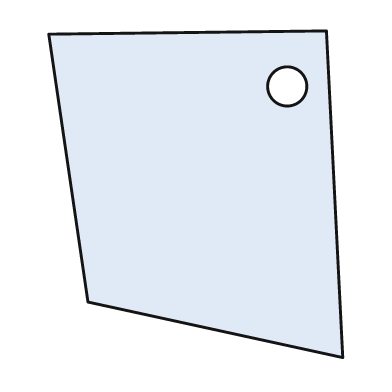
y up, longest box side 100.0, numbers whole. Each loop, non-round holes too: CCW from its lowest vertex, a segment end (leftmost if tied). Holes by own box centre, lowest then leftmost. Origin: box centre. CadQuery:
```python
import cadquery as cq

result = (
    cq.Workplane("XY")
    .moveTo(45.0, -50.0)
    .lineTo(40.0, 50.0)
    .lineTo(-45.0, 49.0)
    .lineTo(-33.0, -33.0)
    .close()
    .moveTo(28.0, 33.0)
    .circle(6.0)
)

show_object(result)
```